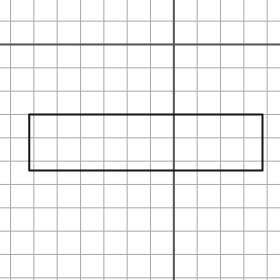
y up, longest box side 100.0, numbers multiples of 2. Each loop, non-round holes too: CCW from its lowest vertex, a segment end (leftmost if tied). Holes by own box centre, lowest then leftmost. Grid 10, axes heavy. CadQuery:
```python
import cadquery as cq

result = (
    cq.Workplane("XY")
    .moveTo(-62.0, -54.0)
    .lineTo(38.0, -54.0)
    .lineTo(38.0, -30.0)
    .lineTo(-62.0, -30.0)
    .close()
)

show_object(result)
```